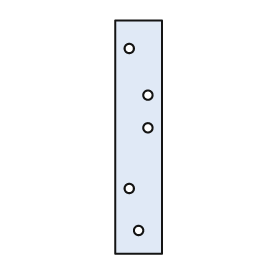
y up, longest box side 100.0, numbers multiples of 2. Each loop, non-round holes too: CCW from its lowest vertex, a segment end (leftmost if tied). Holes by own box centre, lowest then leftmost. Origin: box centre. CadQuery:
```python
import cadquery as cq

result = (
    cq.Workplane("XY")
    .moveTo(-10.0, -50.0)
    .lineTo(10.0, -50.0)
    .lineTo(10.0, 50.0)
    .lineTo(-10.0, 50.0)
    .close()
    .moveTo(0.0, -40.0)
    .circle(2.0)
    .moveTo(-4.0, -22.0)
    .circle(2.0)
    .moveTo(4.0, 4.0)
    .circle(2.0)
    .moveTo(4.0, 18.0)
    .circle(2.0)
    .moveTo(-4.0, 38.0)
    .circle(2.0)
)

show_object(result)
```